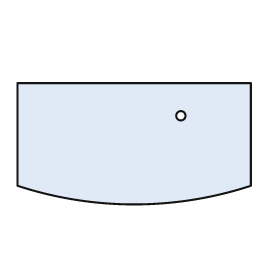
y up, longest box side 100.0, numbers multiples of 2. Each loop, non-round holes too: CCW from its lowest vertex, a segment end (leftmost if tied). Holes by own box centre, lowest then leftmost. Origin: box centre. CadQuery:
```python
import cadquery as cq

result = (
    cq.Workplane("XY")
    .moveTo(-50.0, -18.0)
    .threePointArc((0.0, -26.0), (50.0, -18.0))
    .lineTo(50.0, 26.0)
    .lineTo(-50.0, 26.0)
    .close()
    .moveTo(20.0, 12.0)
    .circle(2.0)
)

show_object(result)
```